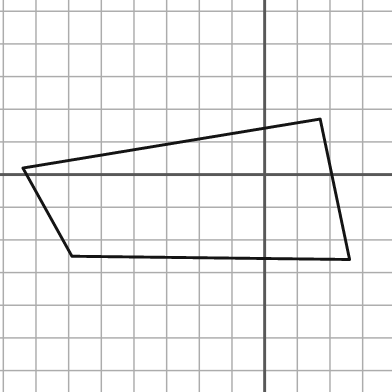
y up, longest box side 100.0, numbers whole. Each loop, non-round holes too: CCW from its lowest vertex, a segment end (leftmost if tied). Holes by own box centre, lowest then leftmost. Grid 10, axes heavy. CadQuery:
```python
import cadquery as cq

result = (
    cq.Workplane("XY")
    .moveTo(26.0, -26.0)
    .lineTo(17.0, 17.0)
    .lineTo(-74.0, 2.0)
    .lineTo(-59.0, -25.0)
    .close()
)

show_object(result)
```